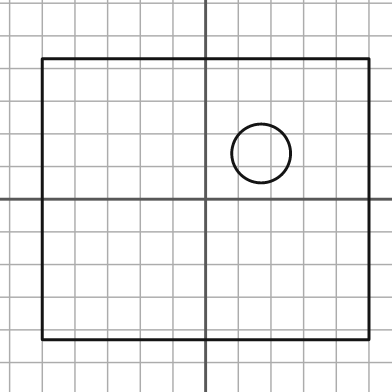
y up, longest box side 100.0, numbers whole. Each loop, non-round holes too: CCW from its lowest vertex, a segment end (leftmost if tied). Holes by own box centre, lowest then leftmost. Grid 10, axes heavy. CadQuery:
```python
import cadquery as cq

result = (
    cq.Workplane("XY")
    .moveTo(-50.0, -43.0)
    .lineTo(50.0, -43.0)
    .lineTo(50.0, 43.0)
    .lineTo(-50.0, 43.0)
    .close()
    .moveTo(17.0, 14.0)
    .circle(9.0)
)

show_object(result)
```